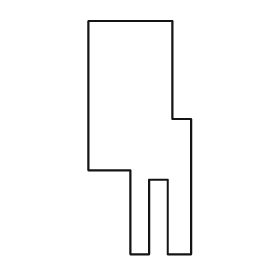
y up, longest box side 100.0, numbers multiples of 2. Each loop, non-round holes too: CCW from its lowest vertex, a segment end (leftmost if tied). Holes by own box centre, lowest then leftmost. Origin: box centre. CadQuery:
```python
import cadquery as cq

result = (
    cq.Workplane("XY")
    .moveTo(-4.0, -50.0)
    .lineTo(4.0, -50.0)
    .lineTo(4.0, -18.0)
    .lineTo(12.0, -18.0)
    .lineTo(12.0, -50.0)
    .lineTo(22.0, -50.0)
    .lineTo(22.0, 8.0)
    .lineTo(14.0, 8.0)
    .lineTo(14.0, 50.0)
    .lineTo(-22.0, 50.0)
    .lineTo(-22.0, -14.0)
    .lineTo(-4.0, -14.0)
    .close()
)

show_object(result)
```